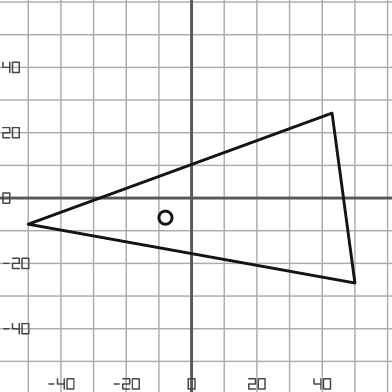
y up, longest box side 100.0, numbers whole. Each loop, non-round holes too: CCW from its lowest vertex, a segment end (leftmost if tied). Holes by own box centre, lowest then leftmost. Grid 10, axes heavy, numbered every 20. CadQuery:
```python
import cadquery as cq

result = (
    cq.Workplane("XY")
    .moveTo(50.0, -26.0)
    .lineTo(43.0, 26.0)
    .lineTo(-50.0, -8.0)
    .close()
    .moveTo(-8.0, -6.0)
    .circle(2.0)
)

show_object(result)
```